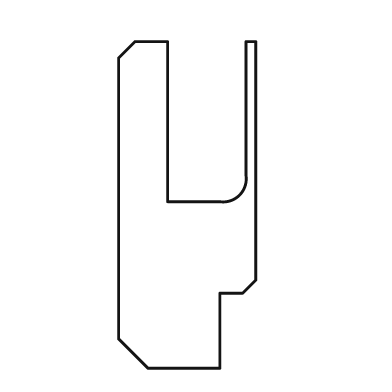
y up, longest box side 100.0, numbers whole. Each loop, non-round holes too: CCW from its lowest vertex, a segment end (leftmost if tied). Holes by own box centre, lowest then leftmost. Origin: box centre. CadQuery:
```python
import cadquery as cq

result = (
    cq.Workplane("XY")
    .moveTo(-12.0, -50.0)
    .lineTo(10.0, -50.0)
    .lineTo(10.0, -27.0)
    .lineTo(17.0, -27.0)
    .lineTo(21.0, -23.0)
    .lineTo(21.0, 50.0)
    .lineTo(18.0, 50.0)
    .lineTo(18.0, 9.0)
    .threePointArc((16.0, 3.0), (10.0, 1.0))
    .lineTo(-6.0, 1.0)
    .lineTo(-6.0, 50.0)
    .lineTo(-16.0, 50.0)
    .lineTo(-21.0, 45.0)
    .lineTo(-21.0, -41.0)
    .close()
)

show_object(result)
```